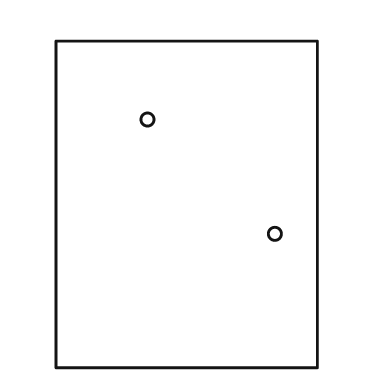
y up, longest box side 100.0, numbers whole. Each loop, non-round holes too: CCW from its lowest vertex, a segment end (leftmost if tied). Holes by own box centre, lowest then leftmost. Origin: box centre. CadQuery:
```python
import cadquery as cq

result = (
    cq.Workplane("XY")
    .moveTo(-40.0, -50.0)
    .lineTo(40.0, -50.0)
    .lineTo(40.0, 50.0)
    .lineTo(-40.0, 50.0)
    .close()
    .moveTo(27.0, -9.0)
    .circle(2.0)
    .moveTo(-12.0, 26.0)
    .circle(2.0)
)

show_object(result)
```